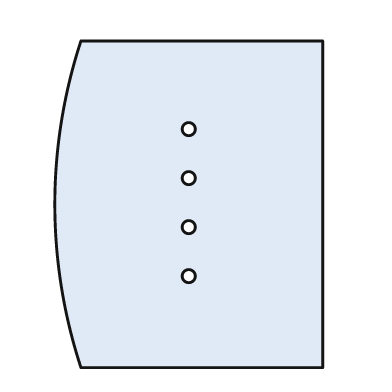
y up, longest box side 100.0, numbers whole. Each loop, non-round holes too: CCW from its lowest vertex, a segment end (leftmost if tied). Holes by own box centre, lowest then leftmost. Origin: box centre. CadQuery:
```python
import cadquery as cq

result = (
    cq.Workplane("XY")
    .moveTo(-33.0, -50.0)
    .lineTo(41.0, -50.0)
    .lineTo(41.0, 50.0)
    .lineTo(-33.0, 50.0)
    .threePointArc((-41.0, 0.0), (-33.0, -50.0))
    .close()
    .moveTo(0.0, -22.0)
    .circle(2.0)
    .moveTo(0.0, -7.0)
    .circle(2.0)
    .moveTo(0.0, 8.0)
    .circle(2.0)
    .moveTo(0.0, 23.0)
    .circle(2.0)
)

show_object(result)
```